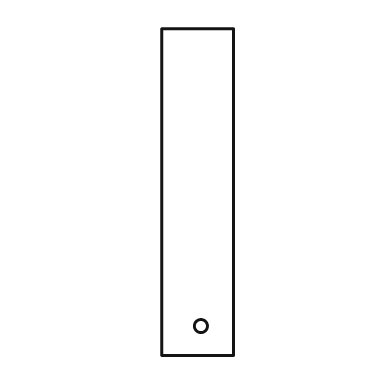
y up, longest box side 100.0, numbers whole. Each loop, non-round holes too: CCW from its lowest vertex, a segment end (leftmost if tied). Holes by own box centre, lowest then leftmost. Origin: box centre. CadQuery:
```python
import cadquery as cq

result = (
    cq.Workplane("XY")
    .moveTo(-11.0, -50.0)
    .lineTo(11.0, -50.0)
    .lineTo(11.0, 50.0)
    .lineTo(-11.0, 50.0)
    .close()
    .moveTo(1.0, -41.0)
    .circle(2.0)
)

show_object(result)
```